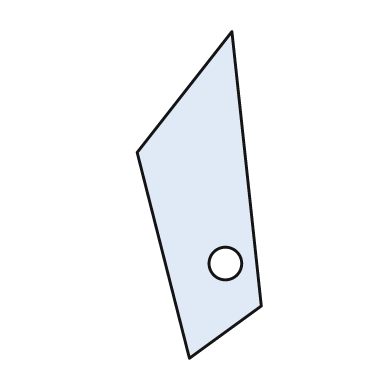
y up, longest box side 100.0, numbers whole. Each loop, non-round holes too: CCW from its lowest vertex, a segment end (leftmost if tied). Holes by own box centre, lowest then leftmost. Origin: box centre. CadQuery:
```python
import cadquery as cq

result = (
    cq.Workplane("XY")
    .moveTo(-3.0, -50.0)
    .lineTo(19.0, -34.0)
    .lineTo(10.0, 50.0)
    .lineTo(-19.0, 13.0)
    .close()
    .moveTo(8.0, -21.0)
    .circle(5.0)
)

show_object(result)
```